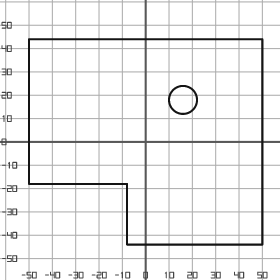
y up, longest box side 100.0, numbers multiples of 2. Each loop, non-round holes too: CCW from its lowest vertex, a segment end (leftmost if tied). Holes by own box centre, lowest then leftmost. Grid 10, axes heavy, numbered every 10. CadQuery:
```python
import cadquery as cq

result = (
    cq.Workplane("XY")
    .moveTo(-8.0, -44.0)
    .lineTo(50.0, -44.0)
    .lineTo(50.0, 44.0)
    .lineTo(-50.0, 44.0)
    .lineTo(-50.0, -18.0)
    .lineTo(-8.0, -18.0)
    .close()
    .moveTo(16.0, 18.0)
    .circle(6.0)
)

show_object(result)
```